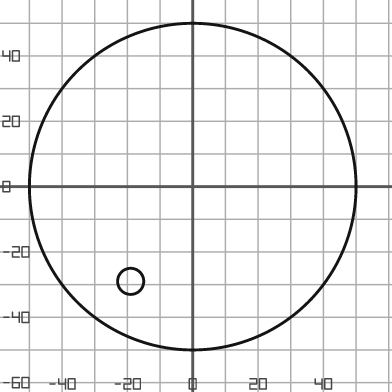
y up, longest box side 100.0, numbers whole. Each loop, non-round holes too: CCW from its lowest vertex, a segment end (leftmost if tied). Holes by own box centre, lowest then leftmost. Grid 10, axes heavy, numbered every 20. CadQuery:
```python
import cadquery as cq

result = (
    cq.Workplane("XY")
    .moveTo(0.0, 0.0)
    .circle(50.0)
    .moveTo(-19.0, -29.0)
    .circle(4.0)
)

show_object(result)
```